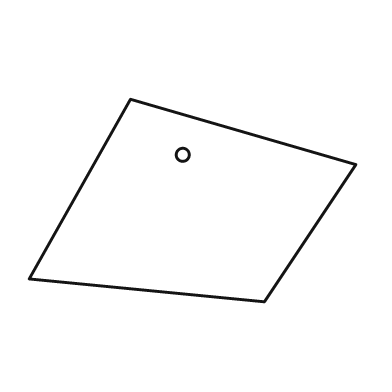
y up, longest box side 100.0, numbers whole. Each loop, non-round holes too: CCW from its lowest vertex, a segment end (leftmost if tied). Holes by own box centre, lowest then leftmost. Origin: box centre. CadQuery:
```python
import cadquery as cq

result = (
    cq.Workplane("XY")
    .moveTo(22.0, -31.0)
    .lineTo(50.0, 11.0)
    .lineTo(-19.0, 31.0)
    .lineTo(-50.0, -24.0)
    .close()
    .moveTo(-3.0, 14.0)
    .circle(2.0)
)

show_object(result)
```